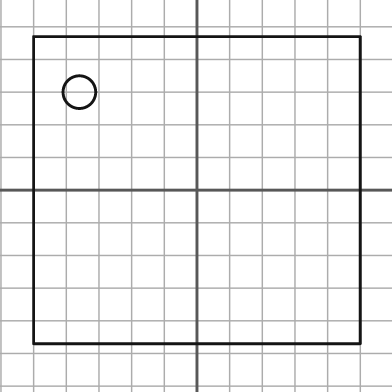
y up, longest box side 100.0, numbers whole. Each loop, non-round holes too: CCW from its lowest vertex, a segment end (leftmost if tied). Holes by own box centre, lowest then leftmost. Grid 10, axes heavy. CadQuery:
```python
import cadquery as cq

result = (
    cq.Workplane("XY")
    .moveTo(-50.0, -47.0)
    .lineTo(50.0, -47.0)
    .lineTo(50.0, 47.0)
    .lineTo(-50.0, 47.0)
    .close()
    .moveTo(-36.0, 30.0)
    .circle(5.0)
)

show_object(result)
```